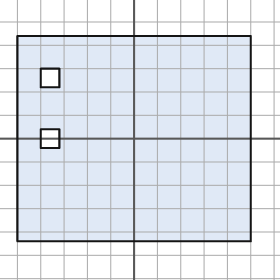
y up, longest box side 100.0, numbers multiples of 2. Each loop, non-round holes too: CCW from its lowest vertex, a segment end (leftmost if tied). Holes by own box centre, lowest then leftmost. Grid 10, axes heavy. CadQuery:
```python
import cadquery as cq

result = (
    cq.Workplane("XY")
    .moveTo(-50.0, -44.0)
    .lineTo(50.0, -44.0)
    .lineTo(50.0, 44.0)
    .lineTo(-50.0, 44.0)
    .close()
    .moveTo(-40.0, -4.0)
    .lineTo(-32.0, -4.0)
    .lineTo(-32.0, 4.0)
    .lineTo(-40.0, 4.0)
    .close()
    .moveTo(-40.0, 22.0)
    .lineTo(-32.0, 22.0)
    .lineTo(-32.0, 30.0)
    .lineTo(-40.0, 30.0)
    .close()
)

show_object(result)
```